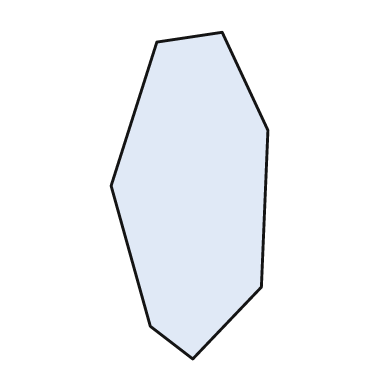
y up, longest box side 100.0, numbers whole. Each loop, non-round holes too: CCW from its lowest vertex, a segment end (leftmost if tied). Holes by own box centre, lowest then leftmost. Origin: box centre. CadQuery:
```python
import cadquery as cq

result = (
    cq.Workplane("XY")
    .moveTo(1.0, -50.0)
    .lineTo(22.0, -28.0)
    .lineTo(24.0, 20.0)
    .lineTo(10.0, 50.0)
    .lineTo(-10.0, 47.0)
    .lineTo(-24.0, 3.0)
    .lineTo(-12.0, -40.0)
    .close()
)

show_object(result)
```